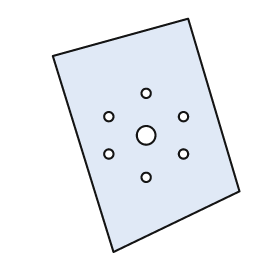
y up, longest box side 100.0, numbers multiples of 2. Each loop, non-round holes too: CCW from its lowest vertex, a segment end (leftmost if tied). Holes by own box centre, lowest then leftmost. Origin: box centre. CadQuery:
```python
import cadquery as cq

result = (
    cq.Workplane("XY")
    .moveTo(-14.0, -50.0)
    .lineTo(40.0, -24.0)
    .lineTo(18.0, 50.0)
    .lineTo(-40.0, 34.0)
    .close()
    .moveTo(0.0, -18.0)
    .circle(2.0)
    .moveTo(-16.0, -8.0)
    .circle(2.0)
    .moveTo(16.0, -8.0)
    .circle(2.0)
    .moveTo(0.0, 0.0)
    .circle(4.0)
    .moveTo(-16.0, 8.0)
    .circle(2.0)
    .moveTo(16.0, 8.0)
    .circle(2.0)
    .moveTo(0.0, 18.0)
    .circle(2.0)
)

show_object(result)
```